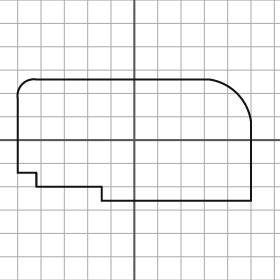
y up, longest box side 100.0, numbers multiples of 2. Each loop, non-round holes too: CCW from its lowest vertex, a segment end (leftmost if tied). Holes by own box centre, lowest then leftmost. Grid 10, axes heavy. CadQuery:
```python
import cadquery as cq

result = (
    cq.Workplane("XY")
    .moveTo(-14.0, -26.0)
    .lineTo(50.0, -26.0)
    .lineTo(50.0, 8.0)
    .threePointArc((44.0, 20.0), (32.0, 26.0))
    .lineTo(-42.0, 26.0)
    .threePointArc((-48.0, 24.0), (-50.0, 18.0))
    .lineTo(-50.0, -14.0)
    .lineTo(-42.0, -14.0)
    .lineTo(-42.0, -20.0)
    .lineTo(-14.0, -20.0)
    .close()
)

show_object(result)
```